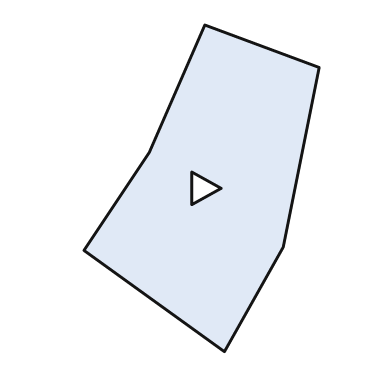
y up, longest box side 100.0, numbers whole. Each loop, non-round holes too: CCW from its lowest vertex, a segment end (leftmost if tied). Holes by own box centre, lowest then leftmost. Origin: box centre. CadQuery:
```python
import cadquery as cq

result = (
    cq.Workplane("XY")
    .moveTo(7.0, -50.0)
    .lineTo(25.0, -18.0)
    .lineTo(36.0, 37.0)
    .lineTo(1.0, 50.0)
    .lineTo(-16.0, 11.0)
    .lineTo(-36.0, -19.0)
    .close()
    .moveTo(-3.0, -5.0)
    .lineTo(6.0, 0.0)
    .lineTo(-3.0, 5.0)
    .close()
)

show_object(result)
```